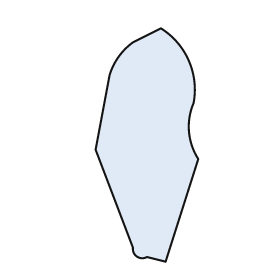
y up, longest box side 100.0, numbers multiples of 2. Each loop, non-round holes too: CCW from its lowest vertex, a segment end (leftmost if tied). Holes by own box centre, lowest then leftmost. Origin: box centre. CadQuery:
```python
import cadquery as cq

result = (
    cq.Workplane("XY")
    .moveTo(8.0, -50.0)
    .lineTo(22.0, -6.0)
    .threePointArc((18.0, 6.0), (20.0, 18.0))
    .threePointArc((18.0, 36.0), (6.0, 50.0))
    .lineTo(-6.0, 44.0)
    .threePointArc((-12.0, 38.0), (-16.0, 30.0))
    .lineTo(-22.0, -2.0)
    .lineTo(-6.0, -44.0)
    .threePointArc((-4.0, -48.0), (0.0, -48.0))
    .close()
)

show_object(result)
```